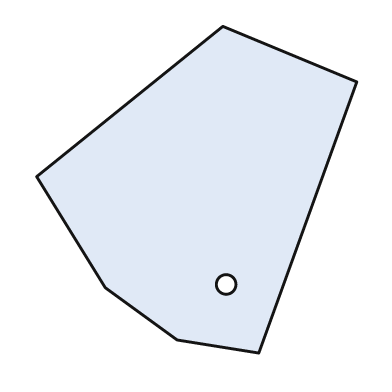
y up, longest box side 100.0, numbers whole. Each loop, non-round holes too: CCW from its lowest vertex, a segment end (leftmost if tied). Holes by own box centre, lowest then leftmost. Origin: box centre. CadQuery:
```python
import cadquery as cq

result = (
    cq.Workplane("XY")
    .moveTo(19.0, -50.0)
    .lineTo(49.0, 33.0)
    .lineTo(8.0, 50.0)
    .lineTo(-49.0, 4.0)
    .lineTo(-28.0, -30.0)
    .lineTo(-6.0, -46.0)
    .close()
    .moveTo(9.0, -29.0)
    .circle(3.0)
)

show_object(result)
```